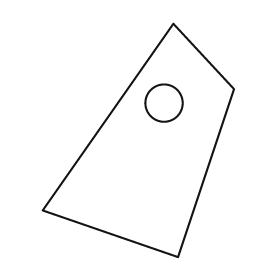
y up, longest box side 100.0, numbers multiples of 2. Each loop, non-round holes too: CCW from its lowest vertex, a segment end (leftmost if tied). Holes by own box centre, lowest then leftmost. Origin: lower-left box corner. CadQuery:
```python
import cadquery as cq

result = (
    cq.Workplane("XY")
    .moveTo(58.0, 0.0)
    .lineTo(82.0, 72.0)
    .lineTo(56.0, 100.0)
    .lineTo(0.0, 20.0)
    .close()
    .moveTo(52.0, 66.0)
    .circle(8.0)
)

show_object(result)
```